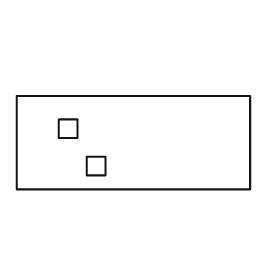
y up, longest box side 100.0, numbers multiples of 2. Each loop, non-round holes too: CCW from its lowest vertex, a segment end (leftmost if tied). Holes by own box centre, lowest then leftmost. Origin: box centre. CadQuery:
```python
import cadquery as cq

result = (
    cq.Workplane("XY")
    .moveTo(-50.0, -20.0)
    .lineTo(50.0, -20.0)
    .lineTo(50.0, 20.0)
    .lineTo(-50.0, 20.0)
    .close()
    .moveTo(-20.0, -14.0)
    .lineTo(-12.0, -14.0)
    .lineTo(-12.0, -6.0)
    .lineTo(-20.0, -6.0)
    .close()
    .moveTo(-32.0, 2.0)
    .lineTo(-24.0, 2.0)
    .lineTo(-24.0, 10.0)
    .lineTo(-32.0, 10.0)
    .close()
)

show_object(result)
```